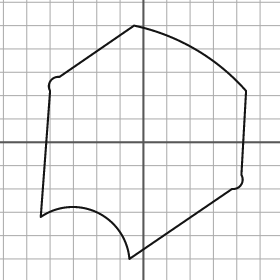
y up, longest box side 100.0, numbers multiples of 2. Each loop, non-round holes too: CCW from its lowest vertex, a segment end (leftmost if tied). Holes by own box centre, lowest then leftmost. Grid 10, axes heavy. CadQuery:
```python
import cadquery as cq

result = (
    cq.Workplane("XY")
    .moveTo(-6.0, -50.0)
    .lineTo(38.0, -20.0)
    .threePointArc((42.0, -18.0), (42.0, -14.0))
    .lineTo(44.0, 22.0)
    .threePointArc((22.0, 40.0), (-4.0, 50.0))
    .lineTo(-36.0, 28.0)
    .threePointArc((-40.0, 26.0), (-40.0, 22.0))
    .lineTo(-44.0, -32.0)
    .threePointArc((-20.0, -30.0), (-6.0, -50.0))
    .close()
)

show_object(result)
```